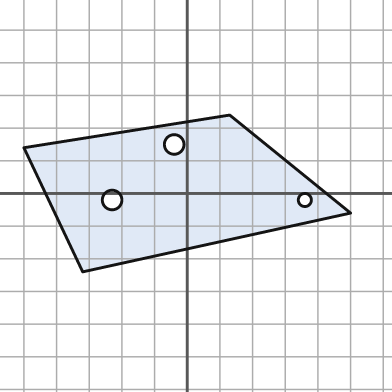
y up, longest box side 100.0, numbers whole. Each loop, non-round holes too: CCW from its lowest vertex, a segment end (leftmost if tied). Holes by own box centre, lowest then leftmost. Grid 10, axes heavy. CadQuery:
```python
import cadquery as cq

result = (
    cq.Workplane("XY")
    .moveTo(-32.0, -24.0)
    .lineTo(50.0, -6.0)
    .lineTo(13.0, 24.0)
    .lineTo(-50.0, 14.0)
    .close()
    .moveTo(-23.0, -2.0)
    .circle(3.0)
    .moveTo(36.0, -2.0)
    .circle(2.0)
    .moveTo(-4.0, 15.0)
    .circle(3.0)
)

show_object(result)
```